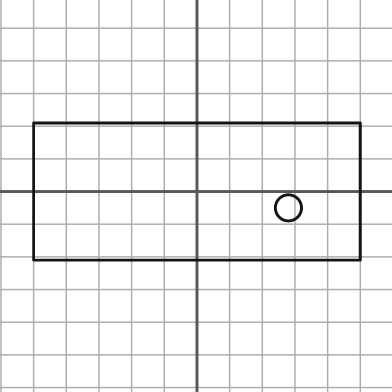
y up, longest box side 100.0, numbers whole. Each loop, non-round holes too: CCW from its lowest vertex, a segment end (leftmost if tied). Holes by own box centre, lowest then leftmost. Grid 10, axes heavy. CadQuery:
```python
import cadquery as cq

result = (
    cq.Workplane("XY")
    .moveTo(-50.0, -21.0)
    .lineTo(50.0, -21.0)
    .lineTo(50.0, 21.0)
    .lineTo(-50.0, 21.0)
    .close()
    .moveTo(28.0, -5.0)
    .circle(4.0)
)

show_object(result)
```